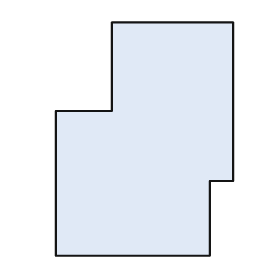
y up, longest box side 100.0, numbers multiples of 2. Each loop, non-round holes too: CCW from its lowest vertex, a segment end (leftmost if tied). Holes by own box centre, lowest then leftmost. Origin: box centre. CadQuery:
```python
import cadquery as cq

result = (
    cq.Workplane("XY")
    .moveTo(-38.0, -50.0)
    .lineTo(28.0, -50.0)
    .lineTo(28.0, -18.0)
    .lineTo(38.0, -18.0)
    .lineTo(38.0, 50.0)
    .lineTo(-14.0, 50.0)
    .lineTo(-14.0, 12.0)
    .lineTo(-38.0, 12.0)
    .close()
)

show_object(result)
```